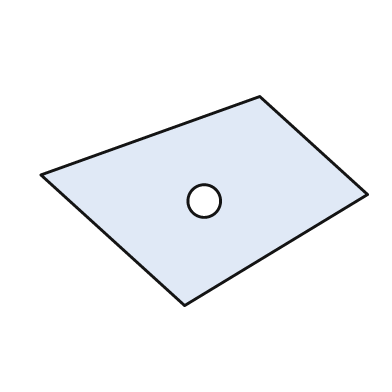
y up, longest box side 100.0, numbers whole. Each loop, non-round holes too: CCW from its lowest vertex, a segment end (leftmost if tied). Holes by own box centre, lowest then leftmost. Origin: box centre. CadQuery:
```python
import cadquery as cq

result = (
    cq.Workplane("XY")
    .moveTo(-6.0, -32.0)
    .lineTo(50.0, 2.0)
    .lineTo(17.0, 32.0)
    .lineTo(-50.0, 8.0)
    .close()
    .moveTo(0.0, 0.0)
    .circle(5.0)
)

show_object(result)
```